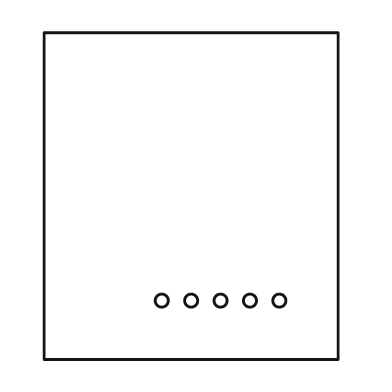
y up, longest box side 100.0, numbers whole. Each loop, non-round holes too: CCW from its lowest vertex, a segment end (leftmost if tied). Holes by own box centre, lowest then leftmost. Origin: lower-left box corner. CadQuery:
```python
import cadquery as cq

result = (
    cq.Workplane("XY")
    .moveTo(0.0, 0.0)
    .lineTo(90.0, 0.0)
    .lineTo(90.0, 100.0)
    .lineTo(0.0, 100.0)
    .close()
    .moveTo(36.0, 18.0)
    .circle(2.0)
    .moveTo(45.0, 18.0)
    .circle(2.0)
    .moveTo(54.0, 18.0)
    .circle(2.0)
    .moveTo(63.0, 18.0)
    .circle(2.0)
    .moveTo(72.0, 18.0)
    .circle(2.0)
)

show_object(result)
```